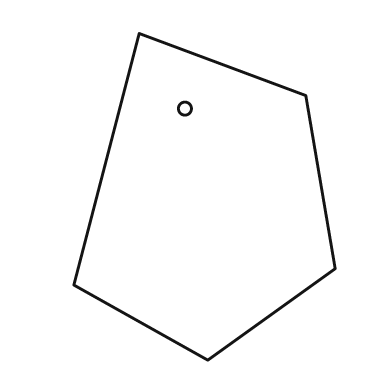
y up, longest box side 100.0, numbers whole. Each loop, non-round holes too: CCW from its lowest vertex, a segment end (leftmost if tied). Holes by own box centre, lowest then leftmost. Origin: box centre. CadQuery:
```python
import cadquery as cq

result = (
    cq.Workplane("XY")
    .moveTo(1.0, -50.0)
    .lineTo(40.0, -22.0)
    .lineTo(31.0, 31.0)
    .lineTo(-20.0, 50.0)
    .lineTo(-40.0, -27.0)
    .close()
    .moveTo(-6.0, 27.0)
    .circle(2.0)
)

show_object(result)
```